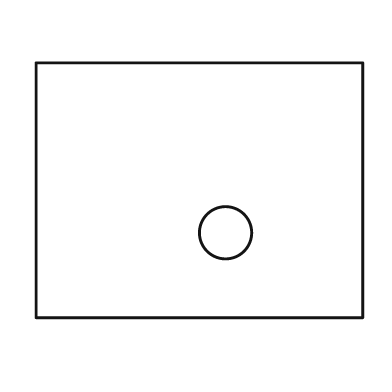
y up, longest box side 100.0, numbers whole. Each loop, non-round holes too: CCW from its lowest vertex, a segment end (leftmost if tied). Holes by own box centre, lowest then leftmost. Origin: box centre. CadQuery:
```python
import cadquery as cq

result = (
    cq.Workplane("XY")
    .moveTo(-50.0, -39.0)
    .lineTo(50.0, -39.0)
    .lineTo(50.0, 39.0)
    .lineTo(-50.0, 39.0)
    .close()
    .moveTo(8.0, -13.0)
    .circle(8.0)
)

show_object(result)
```